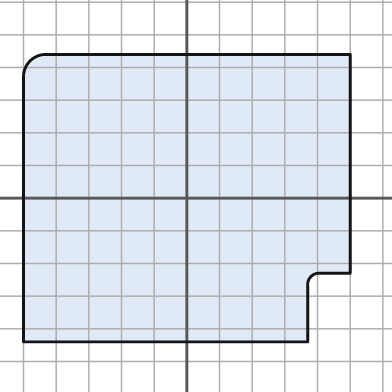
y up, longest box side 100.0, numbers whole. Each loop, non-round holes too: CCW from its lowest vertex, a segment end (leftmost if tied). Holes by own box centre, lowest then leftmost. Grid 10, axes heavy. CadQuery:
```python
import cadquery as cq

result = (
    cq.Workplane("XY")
    .moveTo(-50.0, -44.0)
    .lineTo(37.0, -44.0)
    .lineTo(37.0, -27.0)
    .threePointArc((38.0, -24.0), (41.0, -23.0))
    .lineTo(50.0, -23.0)
    .lineTo(50.0, 44.0)
    .lineTo(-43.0, 44.0)
    .threePointArc((-48.0, 42.0), (-50.0, 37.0))
    .close()
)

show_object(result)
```